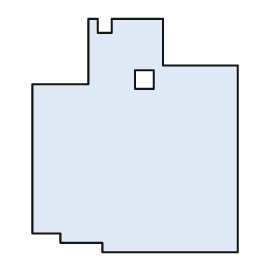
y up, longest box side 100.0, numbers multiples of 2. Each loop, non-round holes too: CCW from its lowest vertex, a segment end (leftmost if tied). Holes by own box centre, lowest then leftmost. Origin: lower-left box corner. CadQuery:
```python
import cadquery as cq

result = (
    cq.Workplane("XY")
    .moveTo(30.0, 0.0)
    .lineTo(88.0, 0.0)
    .lineTo(88.0, 80.0)
    .lineTo(56.0, 80.0)
    .lineTo(56.0, 100.0)
    .lineTo(34.0, 100.0)
    .lineTo(34.0, 94.0)
    .lineTo(28.0, 94.0)
    .lineTo(28.0, 100.0)
    .lineTo(24.0, 100.0)
    .lineTo(24.0, 72.0)
    .lineTo(0.0, 72.0)
    .lineTo(0.0, 8.0)
    .lineTo(12.0, 8.0)
    .lineTo(12.0, 4.0)
    .lineTo(30.0, 4.0)
    .close()
    .moveTo(44.0, 70.0)
    .lineTo(52.0, 70.0)
    .lineTo(52.0, 78.0)
    .lineTo(44.0, 78.0)
    .close()
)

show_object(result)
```